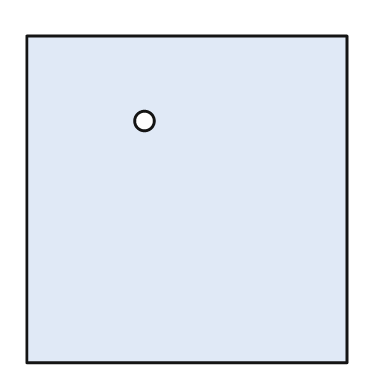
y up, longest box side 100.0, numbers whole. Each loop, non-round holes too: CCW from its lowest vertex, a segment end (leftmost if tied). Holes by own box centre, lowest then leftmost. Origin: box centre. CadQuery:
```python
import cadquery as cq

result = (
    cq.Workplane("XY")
    .moveTo(-49.0, -50.0)
    .lineTo(49.0, -50.0)
    .lineTo(49.0, 50.0)
    .lineTo(-49.0, 50.0)
    .close()
    .moveTo(-13.0, 24.0)
    .circle(3.0)
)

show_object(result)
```